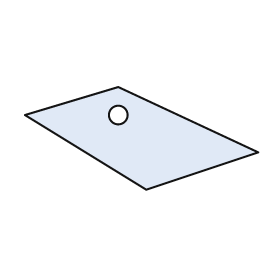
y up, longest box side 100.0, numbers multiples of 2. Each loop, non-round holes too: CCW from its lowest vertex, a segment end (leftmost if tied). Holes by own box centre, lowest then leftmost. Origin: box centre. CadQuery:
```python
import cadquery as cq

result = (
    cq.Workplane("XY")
    .moveTo(2.0, -22.0)
    .lineTo(50.0, -6.0)
    .lineTo(-10.0, 22.0)
    .lineTo(-50.0, 10.0)
    .close()
    .moveTo(-10.0, 10.0)
    .circle(4.0)
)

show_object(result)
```